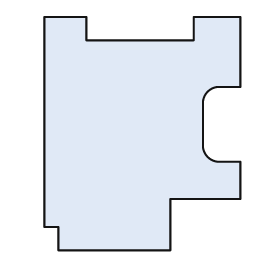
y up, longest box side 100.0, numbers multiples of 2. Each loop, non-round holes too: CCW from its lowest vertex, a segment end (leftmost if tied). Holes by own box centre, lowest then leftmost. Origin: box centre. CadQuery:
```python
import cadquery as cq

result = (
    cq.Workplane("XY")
    .moveTo(-36.0, -50.0)
    .lineTo(12.0, -50.0)
    .lineTo(12.0, -28.0)
    .lineTo(42.0, -28.0)
    .lineTo(42.0, -12.0)
    .lineTo(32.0, -12.0)
    .threePointArc((28.0, -10.0), (26.0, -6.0))
    .lineTo(26.0, 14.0)
    .threePointArc((28.0, 18.0), (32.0, 20.0))
    .lineTo(42.0, 20.0)
    .lineTo(42.0, 50.0)
    .lineTo(22.0, 50.0)
    .lineTo(22.0, 40.0)
    .lineTo(-24.0, 40.0)
    .lineTo(-24.0, 50.0)
    .lineTo(-42.0, 50.0)
    .lineTo(-42.0, -40.0)
    .lineTo(-36.0, -40.0)
    .close()
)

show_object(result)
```